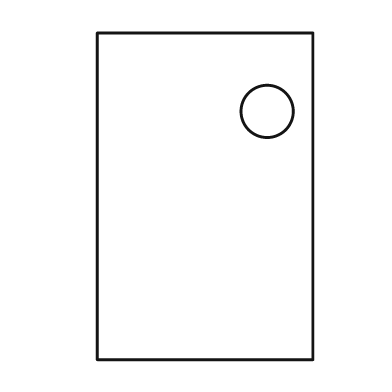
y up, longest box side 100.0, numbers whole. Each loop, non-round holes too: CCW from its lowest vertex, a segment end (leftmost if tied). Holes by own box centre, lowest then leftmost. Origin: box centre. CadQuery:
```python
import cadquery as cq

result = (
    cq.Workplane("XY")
    .moveTo(-33.0, -50.0)
    .lineTo(33.0, -50.0)
    .lineTo(33.0, 50.0)
    .lineTo(-33.0, 50.0)
    .close()
    .moveTo(19.0, 26.0)
    .circle(8.0)
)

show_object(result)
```